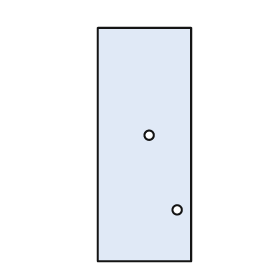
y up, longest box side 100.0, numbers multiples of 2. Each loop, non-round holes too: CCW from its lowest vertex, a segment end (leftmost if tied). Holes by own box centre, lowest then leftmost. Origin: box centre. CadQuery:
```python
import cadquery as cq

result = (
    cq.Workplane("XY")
    .moveTo(-20.0, -50.0)
    .lineTo(20.0, -50.0)
    .lineTo(20.0, 50.0)
    .lineTo(-20.0, 50.0)
    .close()
    .moveTo(14.0, -28.0)
    .circle(2.0)
    .moveTo(2.0, 4.0)
    .circle(2.0)
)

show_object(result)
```